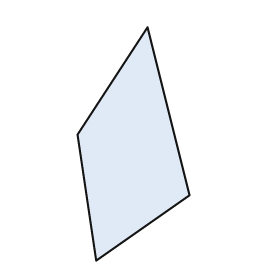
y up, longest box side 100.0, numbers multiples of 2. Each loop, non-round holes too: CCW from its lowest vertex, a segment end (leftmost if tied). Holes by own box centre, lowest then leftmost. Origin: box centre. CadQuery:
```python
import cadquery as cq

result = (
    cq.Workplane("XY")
    .moveTo(-16.0, -50.0)
    .lineTo(24.0, -22.0)
    .lineTo(6.0, 50.0)
    .lineTo(-24.0, 4.0)
    .close()
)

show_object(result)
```